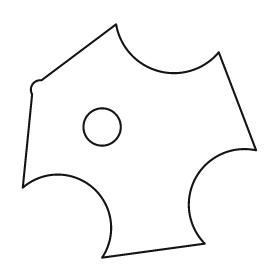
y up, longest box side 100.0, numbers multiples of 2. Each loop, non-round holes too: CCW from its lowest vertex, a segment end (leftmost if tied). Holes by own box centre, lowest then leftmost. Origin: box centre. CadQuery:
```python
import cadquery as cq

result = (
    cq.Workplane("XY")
    .moveTo(-16.0, -50.0)
    .lineTo(28.0, -44.0)
    .threePointArc((24.0, -16.0), (50.0, -4.0))
    .lineTo(34.0, 38.0)
    .threePointArc((8.0, 30.0), (-10.0, 50.0))
    .lineTo(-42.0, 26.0)
    .threePointArc((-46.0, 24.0), (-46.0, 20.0))
    .lineTo(-50.0, -20.0)
    .threePointArc((-20.0, -20.0), (-16.0, -50.0))
    .close()
    .moveTo(-16.0, 6.0)
    .circle(8.0)
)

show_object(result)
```